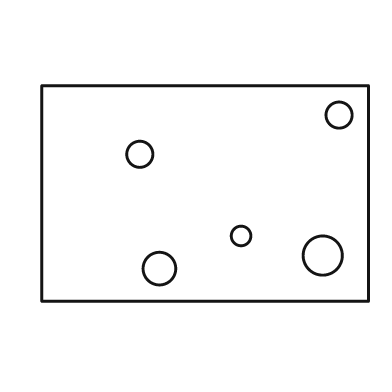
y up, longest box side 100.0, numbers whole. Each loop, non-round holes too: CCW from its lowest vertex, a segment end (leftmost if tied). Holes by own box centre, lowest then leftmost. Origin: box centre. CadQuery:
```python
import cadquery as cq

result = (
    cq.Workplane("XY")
    .moveTo(-50.0, -33.0)
    .lineTo(50.0, -33.0)
    .lineTo(50.0, 33.0)
    .lineTo(-50.0, 33.0)
    .close()
    .moveTo(-14.0, -23.0)
    .circle(5.0)
    .moveTo(36.0, -19.0)
    .circle(6.0)
    .moveTo(11.0, -13.0)
    .circle(3.0)
    .moveTo(-20.0, 12.0)
    .circle(4.0)
    .moveTo(41.0, 24.0)
    .circle(4.0)
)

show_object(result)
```